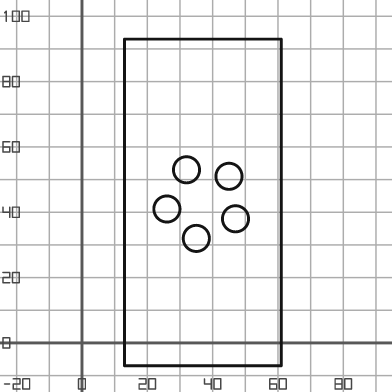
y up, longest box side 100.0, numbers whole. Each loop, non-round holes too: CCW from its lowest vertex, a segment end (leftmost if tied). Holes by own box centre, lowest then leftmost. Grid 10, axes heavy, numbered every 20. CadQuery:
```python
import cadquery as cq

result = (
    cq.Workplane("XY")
    .moveTo(13.0, -7.0)
    .lineTo(61.0, -7.0)
    .lineTo(61.0, 93.0)
    .lineTo(13.0, 93.0)
    .close()
    .moveTo(35.0, 32.0)
    .circle(4.0)
    .moveTo(47.0, 38.0)
    .circle(4.0)
    .moveTo(26.0, 41.0)
    .circle(4.0)
    .moveTo(45.0, 51.0)
    .circle(4.0)
    .moveTo(32.0, 53.0)
    .circle(4.0)
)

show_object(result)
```